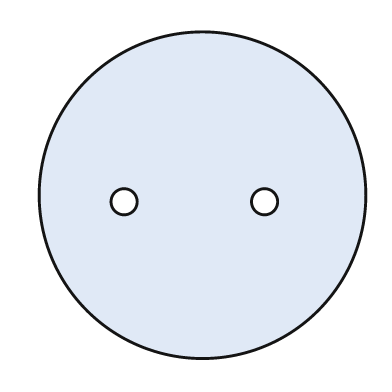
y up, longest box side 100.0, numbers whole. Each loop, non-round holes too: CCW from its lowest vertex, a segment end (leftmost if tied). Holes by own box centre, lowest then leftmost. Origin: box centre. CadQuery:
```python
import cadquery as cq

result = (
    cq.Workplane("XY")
    .moveTo(0.0, 0.0)
    .circle(50.0)
    .moveTo(-24.0, -2.0)
    .circle(4.0)
    .moveTo(19.0, -2.0)
    .circle(4.0)
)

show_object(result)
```